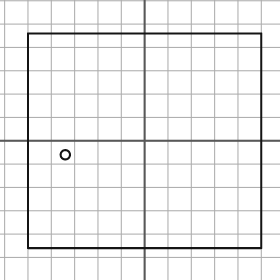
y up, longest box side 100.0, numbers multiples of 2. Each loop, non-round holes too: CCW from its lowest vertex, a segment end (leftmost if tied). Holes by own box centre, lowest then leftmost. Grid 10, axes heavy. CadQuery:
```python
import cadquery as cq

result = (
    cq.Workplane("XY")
    .moveTo(-50.0, -46.0)
    .lineTo(50.0, -46.0)
    .lineTo(50.0, 46.0)
    .lineTo(-50.0, 46.0)
    .close()
    .moveTo(-34.0, -6.0)
    .circle(2.0)
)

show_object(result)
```